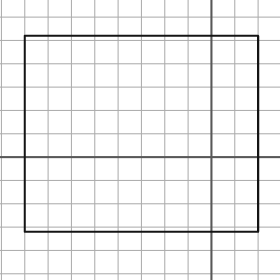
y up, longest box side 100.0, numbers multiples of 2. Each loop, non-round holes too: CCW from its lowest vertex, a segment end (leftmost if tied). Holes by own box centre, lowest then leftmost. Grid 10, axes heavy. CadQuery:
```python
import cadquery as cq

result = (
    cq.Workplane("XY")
    .moveTo(-80.0, -32.0)
    .lineTo(20.0, -32.0)
    .lineTo(20.0, 52.0)
    .lineTo(-80.0, 52.0)
    .close()
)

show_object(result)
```